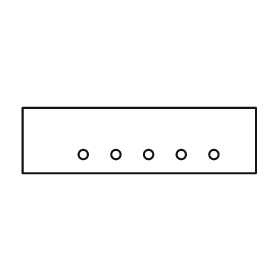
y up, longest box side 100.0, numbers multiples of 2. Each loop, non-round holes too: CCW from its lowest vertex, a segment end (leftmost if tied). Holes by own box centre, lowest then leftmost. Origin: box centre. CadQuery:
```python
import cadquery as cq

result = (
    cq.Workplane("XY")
    .moveTo(-50.0, -14.0)
    .lineTo(50.0, -14.0)
    .lineTo(50.0, 14.0)
    .lineTo(-50.0, 14.0)
    .close()
    .moveTo(-24.0, -6.0)
    .circle(2.0)
    .moveTo(-10.0, -6.0)
    .circle(2.0)
    .moveTo(4.0, -6.0)
    .circle(2.0)
    .moveTo(18.0, -6.0)
    .circle(2.0)
    .moveTo(32.0, -6.0)
    .circle(2.0)
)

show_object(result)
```